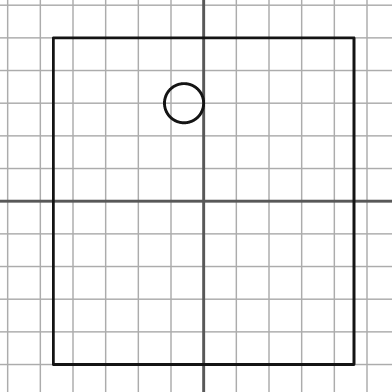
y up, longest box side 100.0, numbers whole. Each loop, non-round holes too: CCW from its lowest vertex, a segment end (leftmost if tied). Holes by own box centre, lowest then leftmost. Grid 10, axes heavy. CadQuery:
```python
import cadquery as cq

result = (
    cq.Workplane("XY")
    .moveTo(-46.0, -50.0)
    .lineTo(46.0, -50.0)
    .lineTo(46.0, 50.0)
    .lineTo(-46.0, 50.0)
    .close()
    .moveTo(-6.0, 30.0)
    .circle(6.0)
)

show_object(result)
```